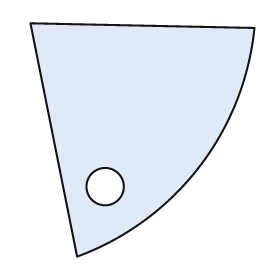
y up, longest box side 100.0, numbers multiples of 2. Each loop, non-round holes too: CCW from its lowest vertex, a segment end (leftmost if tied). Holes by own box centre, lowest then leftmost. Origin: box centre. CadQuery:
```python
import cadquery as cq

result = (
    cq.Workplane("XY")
    .moveTo(-28.0, -50.0)
    .threePointArc((24.0, -12.0), (48.0, 48.0))
    .lineTo(-48.0, 50.0)
    .close()
    .moveTo(-16.0, -20.0)
    .circle(8.0)
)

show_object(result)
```